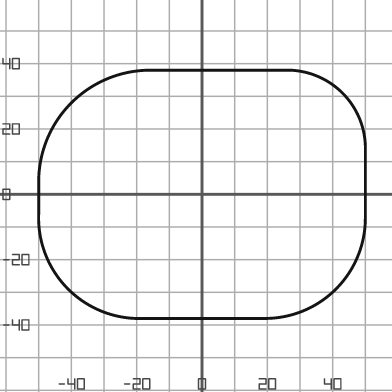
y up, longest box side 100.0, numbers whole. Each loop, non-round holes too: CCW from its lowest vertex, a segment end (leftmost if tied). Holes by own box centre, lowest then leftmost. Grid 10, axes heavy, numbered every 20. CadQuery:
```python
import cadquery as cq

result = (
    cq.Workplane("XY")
    .moveTo(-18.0, -38.0)
    .lineTo(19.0, -38.0)
    .threePointArc((41.0, -29.0), (50.0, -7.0))
    .lineTo(50.0, 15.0)
    .threePointArc((43.0, 31.0), (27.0, 38.0))
    .lineTo(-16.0, 38.0)
    .threePointArc((-40.0, 28.0), (-50.0, 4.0))
    .lineTo(-50.0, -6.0)
    .threePointArc((-41.0, -29.0), (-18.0, -38.0))
    .close()
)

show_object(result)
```